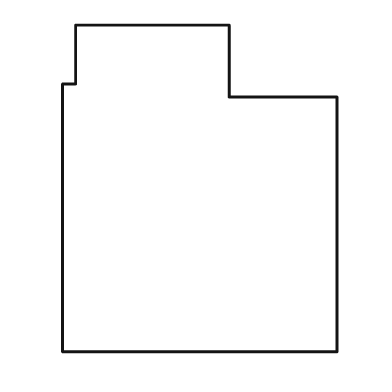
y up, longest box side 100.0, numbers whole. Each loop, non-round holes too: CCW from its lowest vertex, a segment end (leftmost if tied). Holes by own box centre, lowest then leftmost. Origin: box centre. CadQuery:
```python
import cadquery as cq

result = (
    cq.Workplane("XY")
    .moveTo(-42.0, -50.0)
    .lineTo(42.0, -50.0)
    .lineTo(42.0, 28.0)
    .lineTo(9.0, 28.0)
    .lineTo(9.0, 50.0)
    .lineTo(-38.0, 50.0)
    .lineTo(-38.0, 32.0)
    .lineTo(-42.0, 32.0)
    .close()
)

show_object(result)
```